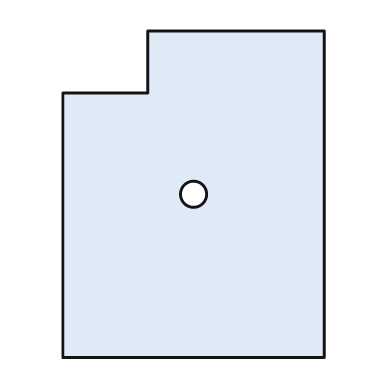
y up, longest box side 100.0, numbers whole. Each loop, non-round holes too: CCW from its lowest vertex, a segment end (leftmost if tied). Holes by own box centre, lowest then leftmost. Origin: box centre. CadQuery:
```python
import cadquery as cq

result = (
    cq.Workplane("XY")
    .moveTo(-40.0, -50.0)
    .lineTo(40.0, -50.0)
    .lineTo(40.0, 50.0)
    .lineTo(-14.0, 50.0)
    .lineTo(-14.0, 31.0)
    .lineTo(-40.0, 31.0)
    .close()
    .moveTo(0.0, 0.0)
    .circle(4.0)
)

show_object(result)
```